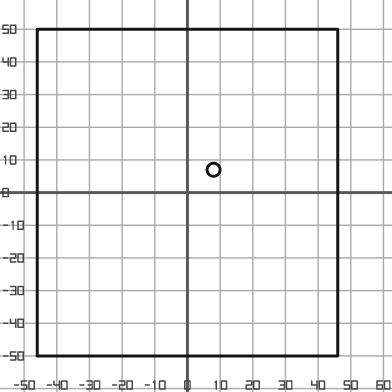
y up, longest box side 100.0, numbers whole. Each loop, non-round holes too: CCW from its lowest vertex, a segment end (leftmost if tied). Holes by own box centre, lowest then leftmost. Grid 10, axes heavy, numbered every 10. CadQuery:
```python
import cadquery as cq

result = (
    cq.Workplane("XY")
    .moveTo(-46.0, -50.0)
    .lineTo(46.0, -50.0)
    .lineTo(46.0, 50.0)
    .lineTo(-46.0, 50.0)
    .close()
    .moveTo(8.0, 7.0)
    .circle(2.0)
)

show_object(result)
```